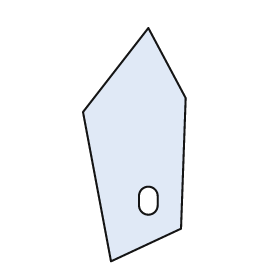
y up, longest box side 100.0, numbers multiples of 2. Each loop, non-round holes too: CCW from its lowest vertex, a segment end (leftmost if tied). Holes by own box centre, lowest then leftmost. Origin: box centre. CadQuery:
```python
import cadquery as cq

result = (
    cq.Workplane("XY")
    .moveTo(-10.0, -50.0)
    .lineTo(20.0, -36.0)
    .lineTo(22.0, 20.0)
    .lineTo(6.0, 50.0)
    .lineTo(-22.0, 14.0)
    .close()
    .moveTo(2.0, -26.0)
    .threePointArc((6.0, -30.0), (10.0, -26.0))
    .lineTo(10.0, -22.0)
    .threePointArc((6.0, -18.0), (2.0, -22.0))
    .close()
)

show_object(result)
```